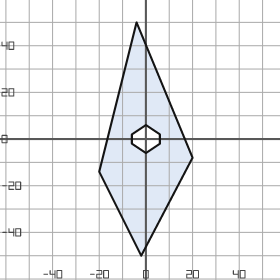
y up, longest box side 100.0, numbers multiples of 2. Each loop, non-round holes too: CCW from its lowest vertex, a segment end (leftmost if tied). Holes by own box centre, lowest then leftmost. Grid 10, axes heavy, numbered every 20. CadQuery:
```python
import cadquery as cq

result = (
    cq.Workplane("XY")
    .moveTo(-2.0, -50.0)
    .lineTo(20.0, -8.0)
    .lineTo(-4.0, 50.0)
    .lineTo(-20.0, -14.0)
    .close()
    .moveTo(0.0, -6.0)
    .lineTo(6.0, -2.0)
    .lineTo(6.0, 2.0)
    .lineTo(0.0, 6.0)
    .lineTo(-6.0, 2.0)
    .lineTo(-6.0, -2.0)
    .close()
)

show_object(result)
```